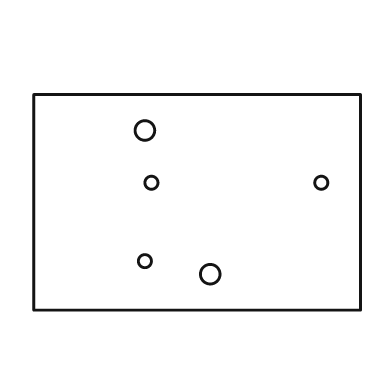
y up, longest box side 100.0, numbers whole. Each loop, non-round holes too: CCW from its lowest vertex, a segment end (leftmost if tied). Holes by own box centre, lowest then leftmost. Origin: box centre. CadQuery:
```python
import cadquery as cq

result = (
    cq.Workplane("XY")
    .moveTo(-50.0, -33.0)
    .lineTo(50.0, -33.0)
    .lineTo(50.0, 33.0)
    .lineTo(-50.0, 33.0)
    .close()
    .moveTo(4.0, -22.0)
    .circle(3.0)
    .moveTo(-16.0, -18.0)
    .circle(2.0)
    .moveTo(-14.0, 6.0)
    .circle(2.0)
    .moveTo(38.0, 6.0)
    .circle(2.0)
    .moveTo(-16.0, 22.0)
    .circle(3.0)
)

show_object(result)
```